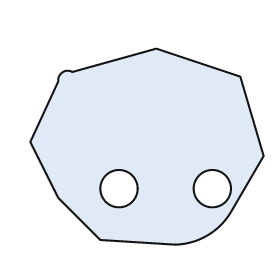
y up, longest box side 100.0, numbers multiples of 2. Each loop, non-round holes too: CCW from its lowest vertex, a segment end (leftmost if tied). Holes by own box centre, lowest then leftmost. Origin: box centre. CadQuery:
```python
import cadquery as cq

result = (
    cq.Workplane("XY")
    .moveTo(12.0, -42.0)
    .threePointArc((26.0, -38.0), (36.0, -28.0))
    .lineTo(50.0, -4.0)
    .lineTo(40.0, 30.0)
    .lineTo(4.0, 42.0)
    .lineTo(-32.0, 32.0)
    .threePointArc((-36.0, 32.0), (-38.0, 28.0))
    .lineTo(-50.0, 2.0)
    .lineTo(-38.0, -22.0)
    .lineTo(-20.0, -40.0)
    .close()
    .moveTo(-12.0, -18.0)
    .circle(8.0)
    .moveTo(28.0, -18.0)
    .circle(8.0)
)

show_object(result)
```